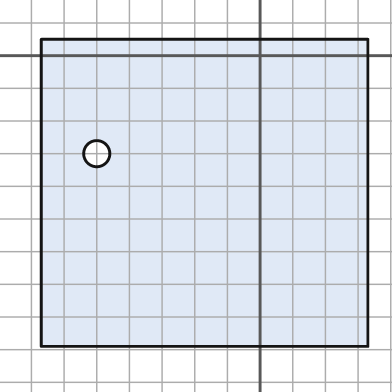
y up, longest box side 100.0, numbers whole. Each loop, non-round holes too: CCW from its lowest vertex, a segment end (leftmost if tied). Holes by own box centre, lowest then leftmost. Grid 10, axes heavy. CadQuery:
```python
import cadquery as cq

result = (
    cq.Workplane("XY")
    .moveTo(-67.0, -89.0)
    .lineTo(33.0, -89.0)
    .lineTo(33.0, 5.0)
    .lineTo(-67.0, 5.0)
    .close()
    .moveTo(-50.0, -30.0)
    .circle(4.0)
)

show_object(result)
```